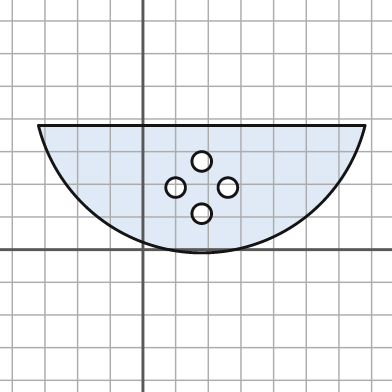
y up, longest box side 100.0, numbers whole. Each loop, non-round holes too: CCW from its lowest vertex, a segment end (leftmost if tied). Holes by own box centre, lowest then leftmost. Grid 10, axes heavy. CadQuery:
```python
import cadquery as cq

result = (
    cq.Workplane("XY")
    .moveTo(-32.0, 38.0)
    .threePointArc((18.0, -1.0), (68.0, 38.0))
    .close()
    .moveTo(18.0, 11.0)
    .circle(3.0)
    .moveTo(10.0, 19.0)
    .circle(3.0)
    .moveTo(26.0, 19.0)
    .circle(3.0)
    .moveTo(18.0, 27.0)
    .circle(3.0)
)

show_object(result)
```